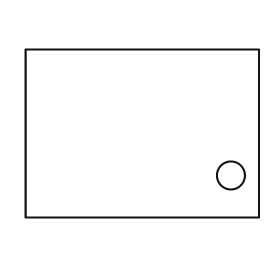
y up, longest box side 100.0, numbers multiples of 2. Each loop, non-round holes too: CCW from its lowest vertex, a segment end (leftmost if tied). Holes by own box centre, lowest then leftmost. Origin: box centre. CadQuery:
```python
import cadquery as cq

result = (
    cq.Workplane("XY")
    .moveTo(-50.0, -36.0)
    .lineTo(50.0, -36.0)
    .lineTo(50.0, 36.0)
    .lineTo(-50.0, 36.0)
    .close()
    .moveTo(38.0, -18.0)
    .circle(6.0)
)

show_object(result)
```